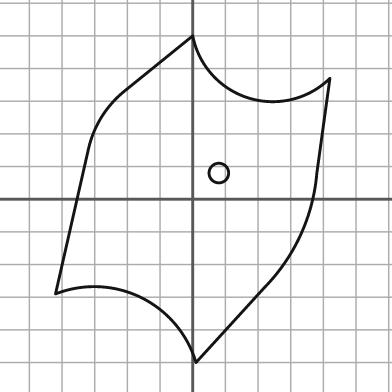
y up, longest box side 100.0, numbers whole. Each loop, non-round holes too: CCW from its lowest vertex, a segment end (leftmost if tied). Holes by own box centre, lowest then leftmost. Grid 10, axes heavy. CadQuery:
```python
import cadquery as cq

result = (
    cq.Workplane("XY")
    .moveTo(1.0, -50.0)
    .lineTo(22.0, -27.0)
    .threePointArc((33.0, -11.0), (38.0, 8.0))
    .lineTo(42.0, 37.0)
    .threePointArc((17.0, 31.0), (0.0, 50.0))
    .lineTo(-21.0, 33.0)
    .threePointArc((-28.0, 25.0), (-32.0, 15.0))
    .lineTo(-42.0, -29.0)
    .threePointArc((-16.0, -30.0), (1.0, -50.0))
    .close()
    .moveTo(8.0, 8.0)
    .circle(3.0)
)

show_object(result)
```